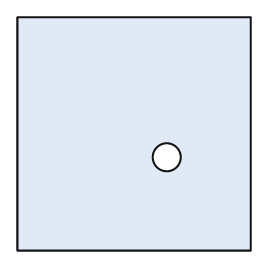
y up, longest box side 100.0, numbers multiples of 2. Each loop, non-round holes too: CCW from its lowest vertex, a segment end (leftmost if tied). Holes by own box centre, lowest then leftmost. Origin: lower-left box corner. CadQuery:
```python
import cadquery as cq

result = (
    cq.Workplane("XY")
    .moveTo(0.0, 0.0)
    .lineTo(100.0, 0.0)
    .lineTo(100.0, 100.0)
    .lineTo(0.0, 100.0)
    .close()
    .moveTo(64.0, 40.0)
    .circle(6.0)
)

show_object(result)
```